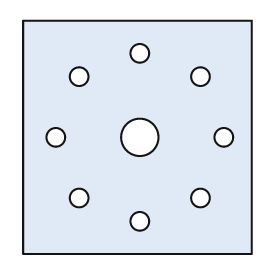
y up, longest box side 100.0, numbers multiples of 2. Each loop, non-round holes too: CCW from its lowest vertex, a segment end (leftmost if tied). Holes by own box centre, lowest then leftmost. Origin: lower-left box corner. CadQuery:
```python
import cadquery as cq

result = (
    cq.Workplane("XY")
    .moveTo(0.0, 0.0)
    .lineTo(98.0, 0.0)
    .lineTo(98.0, 100.0)
    .lineTo(0.0, 100.0)
    .close()
    .moveTo(50.0, 14.0)
    .circle(4.0)
    .moveTo(24.0, 24.0)
    .circle(4.0)
    .moveTo(76.0, 24.0)
    .circle(4.0)
    .moveTo(14.0, 50.0)
    .circle(4.0)
    .moveTo(50.0, 50.0)
    .circle(8.0)
    .moveTo(86.0, 50.0)
    .circle(4.0)
    .moveTo(24.0, 76.0)
    .circle(4.0)
    .moveTo(76.0, 76.0)
    .circle(4.0)
    .moveTo(50.0, 86.0)
    .circle(4.0)
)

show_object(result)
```